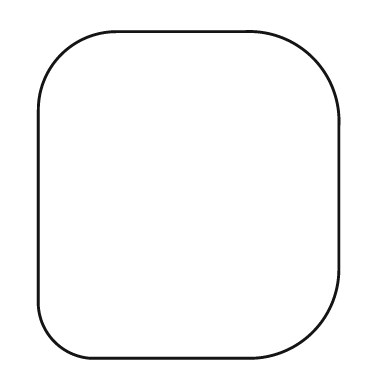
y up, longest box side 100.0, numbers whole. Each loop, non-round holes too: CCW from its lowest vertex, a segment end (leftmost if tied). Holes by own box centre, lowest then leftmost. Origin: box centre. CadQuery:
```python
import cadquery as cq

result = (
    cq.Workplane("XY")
    .moveTo(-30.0, -50.0)
    .lineTo(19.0, -50.0)
    .threePointArc((38.0, -42.0), (46.0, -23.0))
    .lineTo(46.0, 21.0)
    .threePointArc((38.0, 42.0), (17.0, 50.0))
    .lineTo(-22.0, 50.0)
    .threePointArc((-39.0, 43.0), (-46.0, 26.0))
    .lineTo(-46.0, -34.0)
    .threePointArc((-41.0, -45.0), (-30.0, -50.0))
    .close()
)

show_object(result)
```